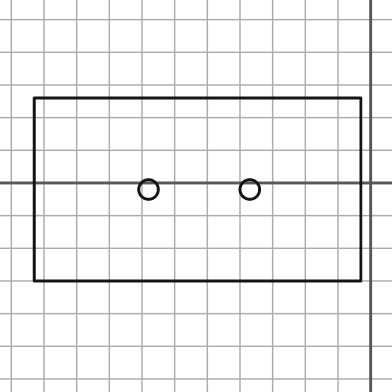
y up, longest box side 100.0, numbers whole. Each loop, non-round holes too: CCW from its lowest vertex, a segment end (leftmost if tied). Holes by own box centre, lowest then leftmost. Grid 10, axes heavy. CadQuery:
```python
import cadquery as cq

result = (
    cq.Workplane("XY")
    .moveTo(-103.0, -30.0)
    .lineTo(-3.0, -30.0)
    .lineTo(-3.0, 26.0)
    .lineTo(-103.0, 26.0)
    .close()
    .moveTo(-68.0, -2.0)
    .circle(3.0)
    .moveTo(-37.0, -2.0)
    .circle(3.0)
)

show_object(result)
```